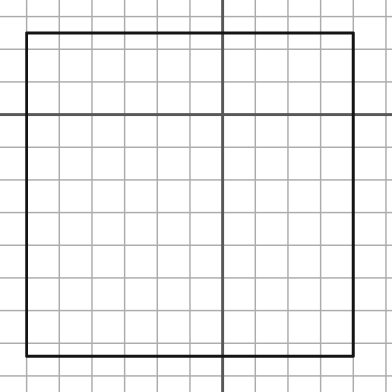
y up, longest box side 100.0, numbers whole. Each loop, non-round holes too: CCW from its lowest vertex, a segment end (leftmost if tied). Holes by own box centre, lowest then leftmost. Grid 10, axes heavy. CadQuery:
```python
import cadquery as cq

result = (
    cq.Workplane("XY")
    .moveTo(-60.0, -74.0)
    .lineTo(40.0, -74.0)
    .lineTo(40.0, 25.0)
    .lineTo(-60.0, 25.0)
    .close()
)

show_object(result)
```